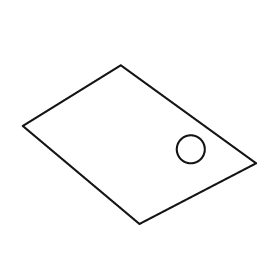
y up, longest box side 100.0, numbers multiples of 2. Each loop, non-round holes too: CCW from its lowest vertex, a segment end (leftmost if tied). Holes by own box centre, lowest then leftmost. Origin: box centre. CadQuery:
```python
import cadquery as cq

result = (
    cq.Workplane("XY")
    .moveTo(0.0, -34.0)
    .lineTo(50.0, -8.0)
    .lineTo(-8.0, 34.0)
    .lineTo(-50.0, 8.0)
    .close()
    .moveTo(22.0, -2.0)
    .circle(6.0)
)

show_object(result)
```